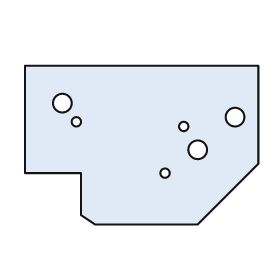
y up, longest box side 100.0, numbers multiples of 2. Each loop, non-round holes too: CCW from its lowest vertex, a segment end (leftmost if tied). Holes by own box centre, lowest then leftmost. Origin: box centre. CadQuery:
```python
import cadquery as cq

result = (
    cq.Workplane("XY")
    .moveTo(-20.0, -34.0)
    .lineTo(24.0, -34.0)
    .lineTo(50.0, -8.0)
    .lineTo(50.0, 34.0)
    .lineTo(-50.0, 34.0)
    .lineTo(-50.0, -12.0)
    .lineTo(-26.0, -12.0)
    .lineTo(-26.0, -30.0)
    .close()
    .moveTo(10.0, -12.0)
    .circle(2.0)
    .moveTo(24.0, -2.0)
    .circle(4.0)
    .moveTo(18.0, 8.0)
    .circle(2.0)
    .moveTo(-28.0, 10.0)
    .circle(2.0)
    .moveTo(40.0, 12.0)
    .circle(4.0)
    .moveTo(-34.0, 18.0)
    .circle(4.0)
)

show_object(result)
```